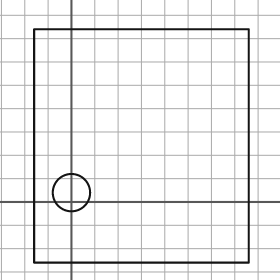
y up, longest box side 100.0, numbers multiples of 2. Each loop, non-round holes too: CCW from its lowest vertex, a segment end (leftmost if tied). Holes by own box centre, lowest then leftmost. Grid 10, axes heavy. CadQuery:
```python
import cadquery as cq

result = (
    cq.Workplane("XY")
    .moveTo(-16.0, -26.0)
    .lineTo(76.0, -26.0)
    .lineTo(76.0, 74.0)
    .lineTo(-16.0, 74.0)
    .close()
    .moveTo(0.0, 4.0)
    .circle(8.0)
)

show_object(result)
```